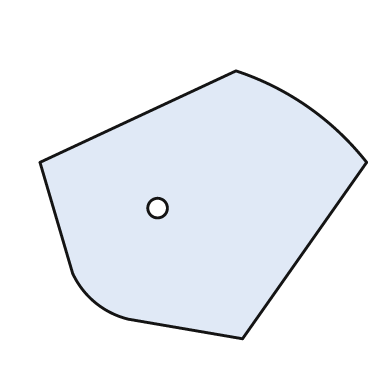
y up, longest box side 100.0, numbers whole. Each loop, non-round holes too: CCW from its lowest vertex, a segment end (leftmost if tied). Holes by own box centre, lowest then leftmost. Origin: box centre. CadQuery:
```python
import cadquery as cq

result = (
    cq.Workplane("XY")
    .moveTo(12.0, -41.0)
    .lineTo(50.0, 13.0)
    .threePointArc((32.0, 30.0), (10.0, 41.0))
    .lineTo(-50.0, 13.0)
    .lineTo(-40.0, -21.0)
    .threePointArc((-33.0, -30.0), (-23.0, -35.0))
    .close()
    .moveTo(-14.0, -1.0)
    .circle(3.0)
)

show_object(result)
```